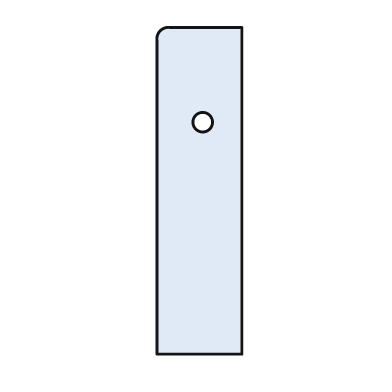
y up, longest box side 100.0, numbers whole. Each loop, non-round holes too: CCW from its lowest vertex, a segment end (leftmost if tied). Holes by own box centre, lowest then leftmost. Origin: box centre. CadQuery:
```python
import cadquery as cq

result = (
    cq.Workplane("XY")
    .moveTo(-13.0, -50.0)
    .lineTo(13.0, -50.0)
    .lineTo(13.0, 50.0)
    .lineTo(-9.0, 50.0)
    .threePointArc((-12.0, 49.0), (-13.0, 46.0))
    .close()
    .moveTo(1.0, 21.0)
    .circle(3.0)
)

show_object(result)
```